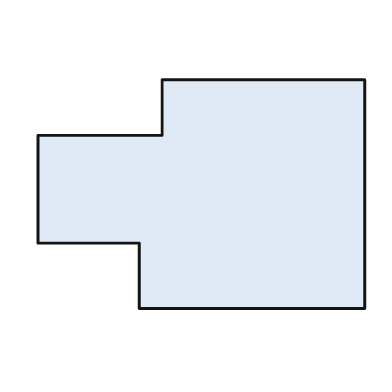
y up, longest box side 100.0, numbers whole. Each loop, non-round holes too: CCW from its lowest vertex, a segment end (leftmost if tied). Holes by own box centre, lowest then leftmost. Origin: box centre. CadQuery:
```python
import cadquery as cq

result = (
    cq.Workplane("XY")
    .moveTo(-19.0, -35.0)
    .lineTo(50.0, -35.0)
    .lineTo(50.0, 35.0)
    .lineTo(-12.0, 35.0)
    .lineTo(-12.0, 18.0)
    .lineTo(-50.0, 18.0)
    .lineTo(-50.0, -15.0)
    .lineTo(-19.0, -15.0)
    .close()
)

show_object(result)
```